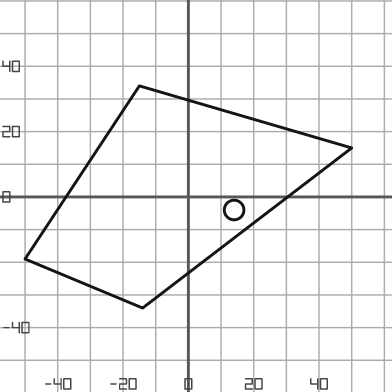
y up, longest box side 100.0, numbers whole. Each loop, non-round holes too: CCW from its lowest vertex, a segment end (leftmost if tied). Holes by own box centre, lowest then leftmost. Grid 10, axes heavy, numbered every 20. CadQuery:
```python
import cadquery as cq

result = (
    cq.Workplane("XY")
    .moveTo(-14.0, -34.0)
    .lineTo(50.0, 15.0)
    .lineTo(-15.0, 34.0)
    .lineTo(-50.0, -19.0)
    .close()
    .moveTo(14.0, -4.0)
    .circle(3.0)
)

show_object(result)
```